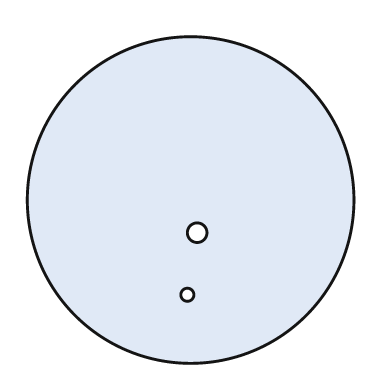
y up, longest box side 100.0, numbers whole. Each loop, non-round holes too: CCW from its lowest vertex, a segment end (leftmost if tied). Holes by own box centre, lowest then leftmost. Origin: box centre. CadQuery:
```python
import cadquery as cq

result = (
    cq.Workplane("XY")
    .moveTo(0.0, 0.0)
    .circle(50.0)
    .moveTo(-1.0, -29.0)
    .circle(2.0)
    .moveTo(2.0, -10.0)
    .circle(3.0)
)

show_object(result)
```